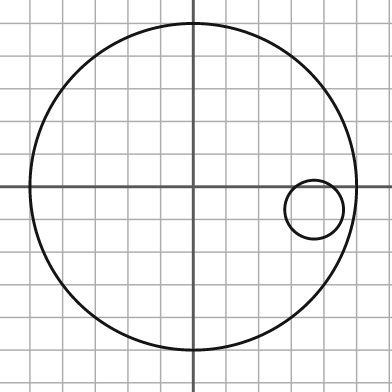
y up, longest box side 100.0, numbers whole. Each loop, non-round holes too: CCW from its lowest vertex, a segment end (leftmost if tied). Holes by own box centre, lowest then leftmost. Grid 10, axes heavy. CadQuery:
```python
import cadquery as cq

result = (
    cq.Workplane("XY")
    .moveTo(0.0, 0.0)
    .circle(50.0)
    .moveTo(37.0, -7.0)
    .circle(9.0)
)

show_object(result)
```